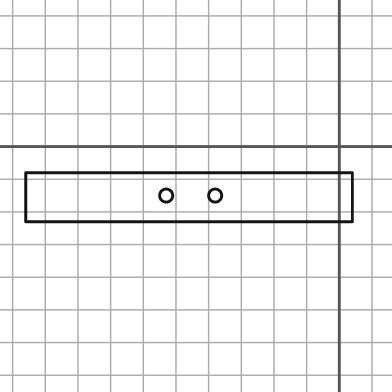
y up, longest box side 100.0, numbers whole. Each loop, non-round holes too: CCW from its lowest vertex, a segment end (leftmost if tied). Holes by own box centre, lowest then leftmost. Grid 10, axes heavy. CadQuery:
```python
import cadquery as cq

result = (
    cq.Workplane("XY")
    .moveTo(-96.0, -23.0)
    .lineTo(4.0, -23.0)
    .lineTo(4.0, -8.0)
    .lineTo(-96.0, -8.0)
    .close()
    .moveTo(-53.0, -15.0)
    .circle(2.0)
    .moveTo(-38.0, -15.0)
    .circle(2.0)
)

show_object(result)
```